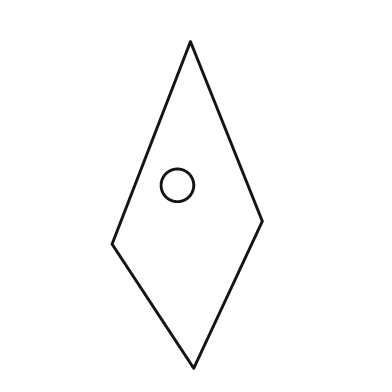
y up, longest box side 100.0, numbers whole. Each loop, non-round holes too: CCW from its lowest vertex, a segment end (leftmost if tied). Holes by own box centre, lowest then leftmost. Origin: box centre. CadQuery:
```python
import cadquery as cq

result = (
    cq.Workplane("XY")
    .moveTo(2.0, -50.0)
    .lineTo(23.0, -5.0)
    .lineTo(1.0, 50.0)
    .lineTo(-23.0, -12.0)
    .close()
    .moveTo(-3.0, 6.0)
    .circle(5.0)
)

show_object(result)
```